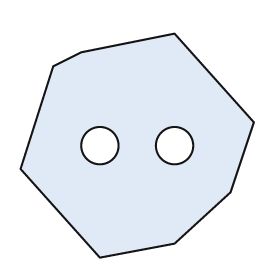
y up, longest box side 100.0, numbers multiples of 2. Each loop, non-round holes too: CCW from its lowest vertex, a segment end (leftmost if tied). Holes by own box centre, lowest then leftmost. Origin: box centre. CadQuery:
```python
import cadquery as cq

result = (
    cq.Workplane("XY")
    .moveTo(-16.0, -48.0)
    .lineTo(16.0, -42.0)
    .lineTo(40.0, -20.0)
    .lineTo(50.0, 10.0)
    .lineTo(16.0, 48.0)
    .lineTo(-24.0, 40.0)
    .lineTo(-36.0, 34.0)
    .lineTo(-50.0, -10.0)
    .close()
    .moveTo(-16.0, 0.0)
    .circle(8.0)
    .moveTo(16.0, 0.0)
    .circle(8.0)
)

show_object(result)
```